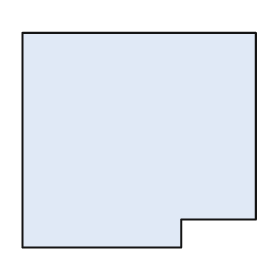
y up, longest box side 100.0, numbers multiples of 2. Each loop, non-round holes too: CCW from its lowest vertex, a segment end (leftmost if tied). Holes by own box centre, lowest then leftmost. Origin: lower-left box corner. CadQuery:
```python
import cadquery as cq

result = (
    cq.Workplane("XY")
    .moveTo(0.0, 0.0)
    .lineTo(68.0, 0.0)
    .lineTo(68.0, 12.0)
    .lineTo(100.0, 12.0)
    .lineTo(100.0, 92.0)
    .lineTo(0.0, 92.0)
    .close()
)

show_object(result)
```